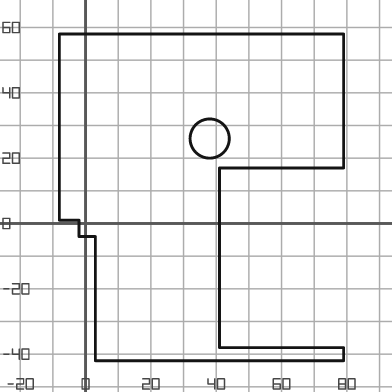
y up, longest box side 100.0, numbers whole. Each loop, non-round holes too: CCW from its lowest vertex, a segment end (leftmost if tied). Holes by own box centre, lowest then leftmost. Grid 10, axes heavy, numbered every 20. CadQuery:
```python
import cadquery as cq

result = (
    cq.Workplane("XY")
    .moveTo(3.0, -42.0)
    .lineTo(79.0, -42.0)
    .lineTo(79.0, -38.0)
    .lineTo(41.0, -38.0)
    .lineTo(41.0, 17.0)
    .lineTo(79.0, 17.0)
    .lineTo(79.0, 58.0)
    .lineTo(-8.0, 58.0)
    .lineTo(-8.0, 1.0)
    .lineTo(-2.0, 1.0)
    .lineTo(-2.0, -4.0)
    .lineTo(3.0, -4.0)
    .close()
    .moveTo(38.0, 26.0)
    .circle(6.0)
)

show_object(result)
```